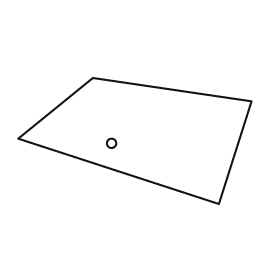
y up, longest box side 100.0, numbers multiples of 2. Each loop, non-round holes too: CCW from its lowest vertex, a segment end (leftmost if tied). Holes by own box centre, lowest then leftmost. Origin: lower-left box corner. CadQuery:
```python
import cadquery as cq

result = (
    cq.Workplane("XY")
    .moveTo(86.0, 0.0)
    .lineTo(100.0, 44.0)
    .lineTo(32.0, 54.0)
    .lineTo(0.0, 28.0)
    .close()
    .moveTo(40.0, 26.0)
    .circle(2.0)
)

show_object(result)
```